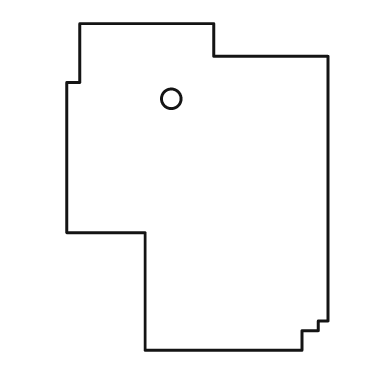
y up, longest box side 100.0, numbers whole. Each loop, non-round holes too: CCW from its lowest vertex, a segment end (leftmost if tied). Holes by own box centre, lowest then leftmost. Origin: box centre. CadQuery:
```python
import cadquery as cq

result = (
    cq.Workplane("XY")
    .moveTo(-16.0, -50.0)
    .lineTo(32.0, -50.0)
    .lineTo(32.0, -44.0)
    .lineTo(37.0, -44.0)
    .lineTo(37.0, -41.0)
    .lineTo(40.0, -41.0)
    .lineTo(40.0, 40.0)
    .lineTo(5.0, 40.0)
    .lineTo(5.0, 50.0)
    .lineTo(-36.0, 50.0)
    .lineTo(-36.0, 32.0)
    .lineTo(-40.0, 32.0)
    .lineTo(-40.0, -14.0)
    .lineTo(-16.0, -14.0)
    .close()
    .moveTo(-8.0, 27.0)
    .circle(3.0)
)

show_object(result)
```